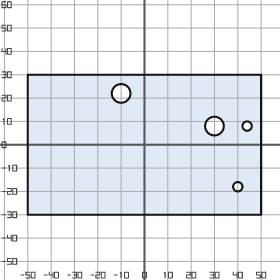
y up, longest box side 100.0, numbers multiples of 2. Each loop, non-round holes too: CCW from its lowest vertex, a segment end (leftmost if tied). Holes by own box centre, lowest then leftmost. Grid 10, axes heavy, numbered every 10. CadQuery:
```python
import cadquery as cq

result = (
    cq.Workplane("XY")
    .moveTo(-50.0, -30.0)
    .lineTo(50.0, -30.0)
    .lineTo(50.0, 30.0)
    .lineTo(-50.0, 30.0)
    .close()
    .moveTo(40.0, -18.0)
    .circle(2.0)
    .moveTo(30.0, 8.0)
    .circle(4.0)
    .moveTo(44.0, 8.0)
    .circle(2.0)
    .moveTo(-10.0, 22.0)
    .circle(4.0)
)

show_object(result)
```